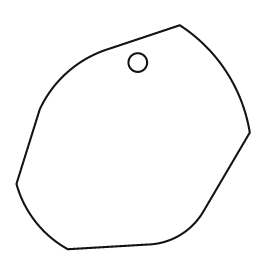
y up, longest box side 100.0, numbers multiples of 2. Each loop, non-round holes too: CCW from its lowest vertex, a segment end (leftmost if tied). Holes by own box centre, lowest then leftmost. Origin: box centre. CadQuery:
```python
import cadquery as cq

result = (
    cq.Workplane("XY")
    .moveTo(-28.0, -48.0)
    .lineTo(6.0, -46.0)
    .threePointArc((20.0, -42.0), (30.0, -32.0))
    .lineTo(50.0, 2.0)
    .threePointArc((40.0, 28.0), (20.0, 48.0))
    .lineTo(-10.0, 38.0)
    .threePointArc((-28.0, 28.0), (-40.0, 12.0))
    .lineTo(-50.0, -20.0)
    .threePointArc((-42.0, -36.0), (-28.0, -48.0))
    .close()
    .moveTo(2.0, 32.0)
    .circle(4.0)
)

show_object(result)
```